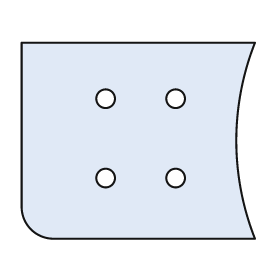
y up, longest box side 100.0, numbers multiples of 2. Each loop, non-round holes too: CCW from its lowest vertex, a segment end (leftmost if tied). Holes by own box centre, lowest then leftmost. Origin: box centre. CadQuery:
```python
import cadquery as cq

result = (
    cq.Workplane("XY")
    .moveTo(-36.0, -42.0)
    .lineTo(50.0, -42.0)
    .threePointArc((42.0, 0.0), (50.0, 42.0))
    .lineTo(-50.0, 42.0)
    .lineTo(-50.0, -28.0)
    .threePointArc((-46.0, -38.0), (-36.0, -42.0))
    .close()
    .moveTo(-14.0, -16.0)
    .circle(4.0)
    .moveTo(16.0, -16.0)
    .circle(4.0)
    .moveTo(-14.0, 18.0)
    .circle(4.0)
    .moveTo(16.0, 18.0)
    .circle(4.0)
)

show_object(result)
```